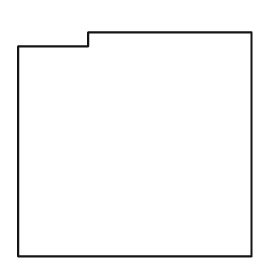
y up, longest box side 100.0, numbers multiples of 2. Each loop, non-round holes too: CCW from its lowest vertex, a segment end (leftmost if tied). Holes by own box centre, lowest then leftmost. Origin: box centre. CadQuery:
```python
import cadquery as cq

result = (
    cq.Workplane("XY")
    .moveTo(-50.0, -48.0)
    .lineTo(50.0, -48.0)
    .lineTo(50.0, 48.0)
    .lineTo(-20.0, 48.0)
    .lineTo(-20.0, 42.0)
    .lineTo(-50.0, 42.0)
    .close()
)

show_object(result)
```